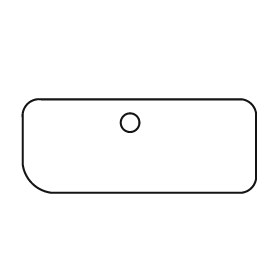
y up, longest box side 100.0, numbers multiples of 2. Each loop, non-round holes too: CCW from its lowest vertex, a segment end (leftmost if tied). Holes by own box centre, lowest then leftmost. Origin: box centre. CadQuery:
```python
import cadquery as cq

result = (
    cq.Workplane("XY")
    .moveTo(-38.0, -20.0)
    .lineTo(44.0, -20.0)
    .threePointArc((48.0, -18.0), (50.0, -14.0))
    .lineTo(50.0, 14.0)
    .threePointArc((48.0, 18.0), (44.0, 20.0))
    .lineTo(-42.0, 20.0)
    .threePointArc((-48.0, 18.0), (-50.0, 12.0))
    .lineTo(-50.0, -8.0)
    .threePointArc((-46.0, -16.0), (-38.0, -20.0))
    .close()
    .moveTo(-4.0, 10.0)
    .circle(4.0)
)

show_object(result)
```